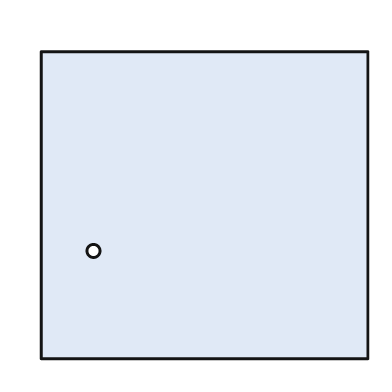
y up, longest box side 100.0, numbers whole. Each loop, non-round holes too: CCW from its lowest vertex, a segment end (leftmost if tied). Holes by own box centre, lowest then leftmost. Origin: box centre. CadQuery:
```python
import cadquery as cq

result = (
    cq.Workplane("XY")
    .moveTo(-50.0, -47.0)
    .lineTo(50.0, -47.0)
    .lineTo(50.0, 47.0)
    .lineTo(-50.0, 47.0)
    .close()
    .moveTo(-34.0, -14.0)
    .circle(2.0)
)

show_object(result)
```